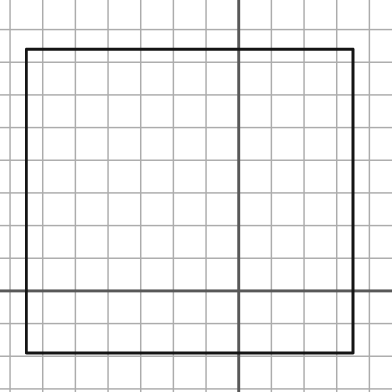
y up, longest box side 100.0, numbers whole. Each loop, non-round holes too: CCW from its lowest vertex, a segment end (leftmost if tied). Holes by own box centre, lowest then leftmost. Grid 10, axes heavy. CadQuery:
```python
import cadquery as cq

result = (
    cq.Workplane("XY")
    .moveTo(-65.0, -19.0)
    .lineTo(35.0, -19.0)
    .lineTo(35.0, 74.0)
    .lineTo(-65.0, 74.0)
    .close()
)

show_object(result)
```